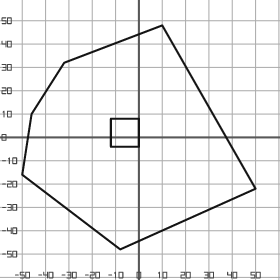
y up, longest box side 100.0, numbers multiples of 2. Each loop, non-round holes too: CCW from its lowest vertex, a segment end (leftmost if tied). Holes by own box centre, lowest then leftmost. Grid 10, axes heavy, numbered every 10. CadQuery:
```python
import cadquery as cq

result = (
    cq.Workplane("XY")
    .moveTo(-8.0, -48.0)
    .lineTo(50.0, -22.0)
    .lineTo(10.0, 48.0)
    .lineTo(-32.0, 32.0)
    .lineTo(-46.0, 10.0)
    .lineTo(-50.0, -16.0)
    .close()
    .moveTo(-12.0, -4.0)
    .lineTo(0.0, -4.0)
    .lineTo(0.0, 8.0)
    .lineTo(-12.0, 8.0)
    .close()
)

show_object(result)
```